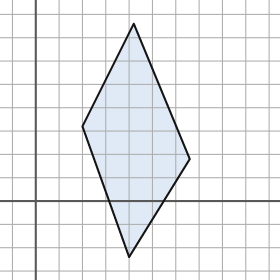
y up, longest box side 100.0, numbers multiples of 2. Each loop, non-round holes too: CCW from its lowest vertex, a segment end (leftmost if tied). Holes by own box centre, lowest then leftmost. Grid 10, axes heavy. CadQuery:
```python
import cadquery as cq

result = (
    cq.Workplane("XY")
    .moveTo(40.0, -24.0)
    .lineTo(66.0, 18.0)
    .lineTo(42.0, 76.0)
    .lineTo(20.0, 32.0)
    .close()
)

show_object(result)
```